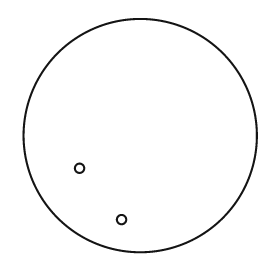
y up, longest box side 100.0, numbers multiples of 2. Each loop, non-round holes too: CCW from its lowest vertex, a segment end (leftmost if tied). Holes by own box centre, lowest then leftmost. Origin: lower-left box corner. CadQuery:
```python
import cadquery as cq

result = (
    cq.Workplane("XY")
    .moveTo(50.0, 50.0)
    .circle(50.0)
    .moveTo(42.0, 14.0)
    .circle(2.0)
    .moveTo(24.0, 36.0)
    .circle(2.0)
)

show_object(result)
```